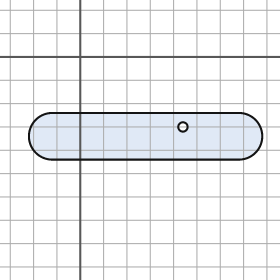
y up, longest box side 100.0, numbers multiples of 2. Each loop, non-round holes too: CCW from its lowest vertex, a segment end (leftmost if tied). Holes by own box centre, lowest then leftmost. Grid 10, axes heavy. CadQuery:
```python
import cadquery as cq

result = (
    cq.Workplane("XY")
    .moveTo(-12.0, -44.0)
    .lineTo(68.0, -44.0)
    .threePointArc((78.0, -34.0), (68.0, -24.0))
    .lineTo(-12.0, -24.0)
    .threePointArc((-22.0, -34.0), (-12.0, -44.0))
    .close()
    .moveTo(44.0, -30.0)
    .circle(2.0)
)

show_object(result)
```